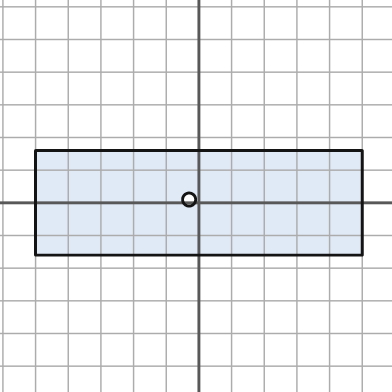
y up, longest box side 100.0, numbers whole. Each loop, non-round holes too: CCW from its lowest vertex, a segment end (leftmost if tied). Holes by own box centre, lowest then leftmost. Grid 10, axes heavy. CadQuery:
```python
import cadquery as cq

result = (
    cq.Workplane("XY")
    .moveTo(-50.0, -16.0)
    .lineTo(50.0, -16.0)
    .lineTo(50.0, 16.0)
    .lineTo(-50.0, 16.0)
    .close()
    .moveTo(-3.0, 1.0)
    .circle(2.0)
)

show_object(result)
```